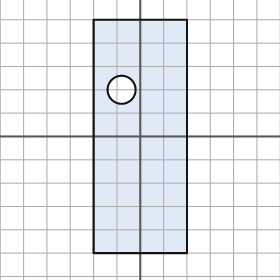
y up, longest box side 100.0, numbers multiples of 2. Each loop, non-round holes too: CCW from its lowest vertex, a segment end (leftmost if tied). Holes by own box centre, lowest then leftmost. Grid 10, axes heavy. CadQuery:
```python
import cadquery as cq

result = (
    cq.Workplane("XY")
    .moveTo(-20.0, -50.0)
    .lineTo(20.0, -50.0)
    .lineTo(20.0, 50.0)
    .lineTo(-20.0, 50.0)
    .close()
    .moveTo(-8.0, 20.0)
    .circle(6.0)
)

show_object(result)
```